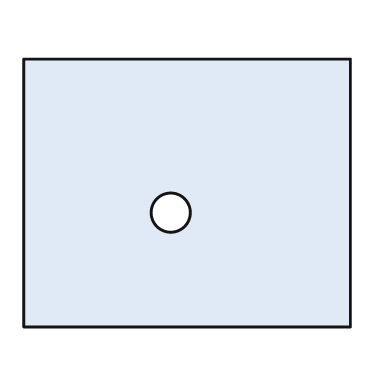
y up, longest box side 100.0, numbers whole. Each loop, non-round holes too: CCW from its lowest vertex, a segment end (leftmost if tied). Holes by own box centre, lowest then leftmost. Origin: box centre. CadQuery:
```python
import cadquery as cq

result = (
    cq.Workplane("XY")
    .moveTo(-50.0, -41.0)
    .lineTo(50.0, -41.0)
    .lineTo(50.0, 41.0)
    .lineTo(-50.0, 41.0)
    .close()
    .moveTo(-5.0, -6.0)
    .circle(6.0)
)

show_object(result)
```